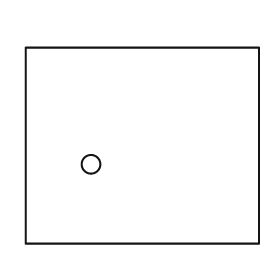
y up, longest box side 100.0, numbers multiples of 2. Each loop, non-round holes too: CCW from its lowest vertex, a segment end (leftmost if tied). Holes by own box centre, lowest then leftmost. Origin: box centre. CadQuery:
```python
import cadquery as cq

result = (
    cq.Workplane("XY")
    .moveTo(-50.0, -42.0)
    .lineTo(50.0, -42.0)
    .lineTo(50.0, 42.0)
    .lineTo(-50.0, 42.0)
    .close()
    .moveTo(-22.0, -8.0)
    .circle(4.0)
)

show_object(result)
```